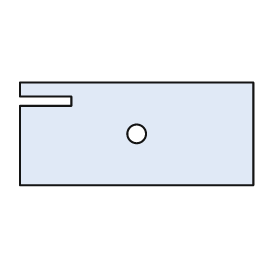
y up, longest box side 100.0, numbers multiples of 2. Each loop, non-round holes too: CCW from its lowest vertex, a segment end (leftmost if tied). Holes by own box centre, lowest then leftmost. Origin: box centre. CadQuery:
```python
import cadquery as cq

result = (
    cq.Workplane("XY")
    .moveTo(-50.0, -22.0)
    .lineTo(50.0, -22.0)
    .lineTo(50.0, 22.0)
    .lineTo(-50.0, 22.0)
    .lineTo(-50.0, 16.0)
    .lineTo(-28.0, 16.0)
    .lineTo(-28.0, 12.0)
    .lineTo(-50.0, 12.0)
    .close()
    .moveTo(0.0, 0.0)
    .circle(4.0)
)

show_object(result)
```